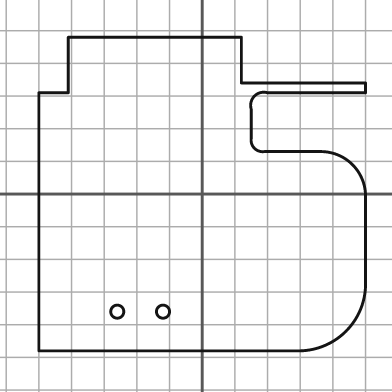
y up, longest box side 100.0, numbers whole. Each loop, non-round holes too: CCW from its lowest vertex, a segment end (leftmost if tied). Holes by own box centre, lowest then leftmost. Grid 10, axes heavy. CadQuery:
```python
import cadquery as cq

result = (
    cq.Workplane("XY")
    .moveTo(-50.0, -48.0)
    .lineTo(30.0, -48.0)
    .threePointArc((44.0, -42.0), (50.0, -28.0))
    .lineTo(50.0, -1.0)
    .threePointArc((46.0, 9.0), (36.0, 13.0))
    .lineTo(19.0, 13.0)
    .threePointArc((16.0, 14.0), (15.0, 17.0))
    .lineTo(15.0, 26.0)
    .threePointArc((16.0, 30.0), (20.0, 31.0))
    .lineTo(50.0, 31.0)
    .lineTo(50.0, 34.0)
    .lineTo(12.0, 34.0)
    .lineTo(12.0, 48.0)
    .lineTo(-41.0, 48.0)
    .lineTo(-41.0, 31.0)
    .lineTo(-50.0, 31.0)
    .close()
    .moveTo(-26.0, -36.0)
    .circle(2.0)
    .moveTo(-12.0, -36.0)
    .circle(2.0)
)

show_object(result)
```